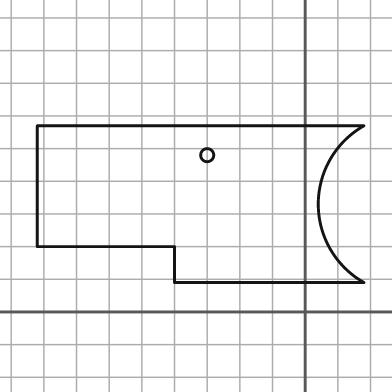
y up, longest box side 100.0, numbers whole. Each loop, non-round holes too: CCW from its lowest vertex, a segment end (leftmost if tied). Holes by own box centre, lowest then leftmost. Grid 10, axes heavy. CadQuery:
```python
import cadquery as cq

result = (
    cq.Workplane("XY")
    .moveTo(-40.0, 9.0)
    .lineTo(18.0, 9.0)
    .threePointArc((4.0, 33.0), (18.0, 57.0))
    .lineTo(-82.0, 57.0)
    .lineTo(-82.0, 20.0)
    .lineTo(-40.0, 20.0)
    .close()
    .moveTo(-30.0, 48.0)
    .circle(2.0)
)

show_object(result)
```